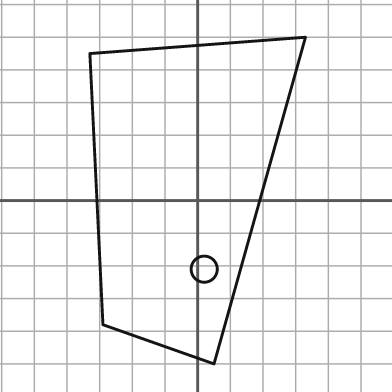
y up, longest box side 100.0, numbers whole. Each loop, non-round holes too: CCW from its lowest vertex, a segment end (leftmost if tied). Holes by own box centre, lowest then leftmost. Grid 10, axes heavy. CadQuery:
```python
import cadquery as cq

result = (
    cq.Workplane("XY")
    .moveTo(5.0, -50.0)
    .lineTo(33.0, 50.0)
    .lineTo(-33.0, 45.0)
    .lineTo(-29.0, -38.0)
    .close()
    .moveTo(2.0, -21.0)
    .circle(4.0)
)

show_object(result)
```